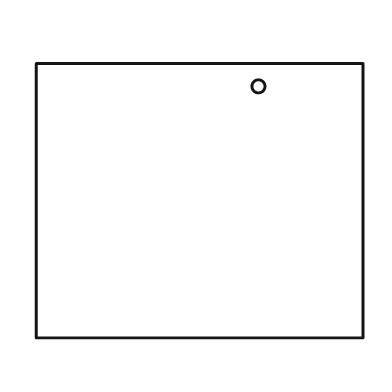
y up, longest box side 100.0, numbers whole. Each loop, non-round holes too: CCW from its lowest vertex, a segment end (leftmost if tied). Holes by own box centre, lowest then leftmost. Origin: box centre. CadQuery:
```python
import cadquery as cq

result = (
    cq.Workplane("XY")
    .moveTo(-50.0, -42.0)
    .lineTo(50.0, -42.0)
    .lineTo(50.0, 42.0)
    .lineTo(-50.0, 42.0)
    .close()
    .moveTo(18.0, 35.0)
    .circle(2.0)
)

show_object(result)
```